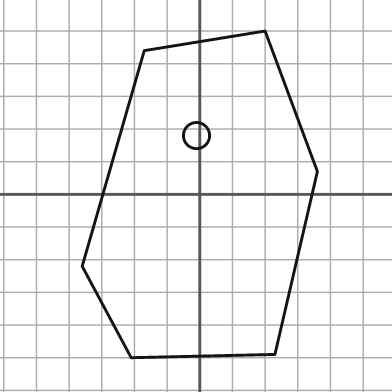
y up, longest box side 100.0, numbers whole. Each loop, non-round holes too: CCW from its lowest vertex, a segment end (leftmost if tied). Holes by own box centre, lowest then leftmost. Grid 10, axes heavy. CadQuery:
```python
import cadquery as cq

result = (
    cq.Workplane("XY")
    .moveTo(-21.0, -50.0)
    .lineTo(23.0, -49.0)
    .lineTo(36.0, 7.0)
    .lineTo(20.0, 50.0)
    .lineTo(-17.0, 44.0)
    .lineTo(-36.0, -22.0)
    .close()
    .moveTo(-1.0, 18.0)
    .circle(4.0)
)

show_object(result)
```